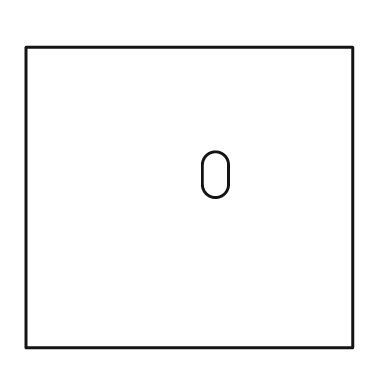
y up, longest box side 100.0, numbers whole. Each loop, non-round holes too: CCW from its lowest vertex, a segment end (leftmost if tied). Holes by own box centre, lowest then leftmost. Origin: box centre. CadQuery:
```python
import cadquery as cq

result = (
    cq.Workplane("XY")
    .moveTo(-50.0, -46.0)
    .lineTo(50.0, -46.0)
    .lineTo(50.0, 46.0)
    .lineTo(-50.0, 46.0)
    .close()
    .moveTo(4.0, 4.0)
    .threePointArc((8.0, 0.0), (12.0, 4.0))
    .lineTo(12.0, 10.0)
    .threePointArc((8.0, 14.0), (4.0, 10.0))
    .close()
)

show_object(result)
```